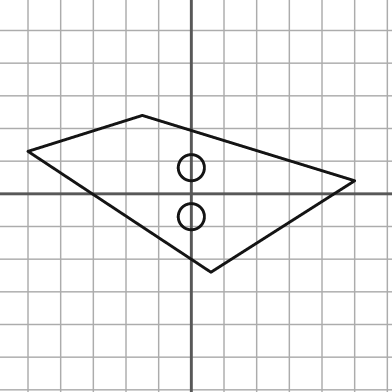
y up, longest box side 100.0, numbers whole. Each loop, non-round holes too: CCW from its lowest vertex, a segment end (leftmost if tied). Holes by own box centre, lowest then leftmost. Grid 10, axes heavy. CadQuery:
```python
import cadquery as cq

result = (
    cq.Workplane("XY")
    .moveTo(6.0, -24.0)
    .lineTo(50.0, 4.0)
    .lineTo(-15.0, 24.0)
    .lineTo(-50.0, 13.0)
    .close()
    .moveTo(0.0, -7.0)
    .circle(4.0)
    .moveTo(0.0, 8.0)
    .circle(4.0)
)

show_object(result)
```